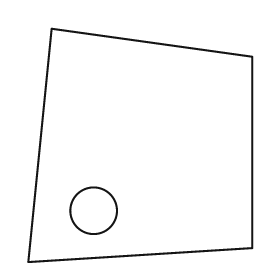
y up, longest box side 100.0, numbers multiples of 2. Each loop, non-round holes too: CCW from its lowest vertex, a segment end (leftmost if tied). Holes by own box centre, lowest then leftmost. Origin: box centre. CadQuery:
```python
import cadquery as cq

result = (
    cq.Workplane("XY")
    .moveTo(-48.0, -50.0)
    .lineTo(48.0, -44.0)
    .lineTo(48.0, 38.0)
    .lineTo(-38.0, 50.0)
    .close()
    .moveTo(-20.0, -28.0)
    .circle(10.0)
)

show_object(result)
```